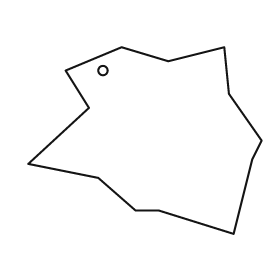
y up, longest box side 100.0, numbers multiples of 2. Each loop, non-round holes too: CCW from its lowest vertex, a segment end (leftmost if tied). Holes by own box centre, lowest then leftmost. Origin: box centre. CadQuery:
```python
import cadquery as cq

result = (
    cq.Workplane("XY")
    .moveTo(38.0, -40.0)
    .lineTo(46.0, -8.0)
    .lineTo(50.0, 0.0)
    .lineTo(36.0, 20.0)
    .lineTo(34.0, 40.0)
    .lineTo(10.0, 34.0)
    .lineTo(-10.0, 40.0)
    .lineTo(-34.0, 30.0)
    .lineTo(-24.0, 14.0)
    .lineTo(-50.0, -10.0)
    .lineTo(-20.0, -16.0)
    .lineTo(-4.0, -30.0)
    .lineTo(6.0, -30.0)
    .close()
    .moveTo(-18.0, 30.0)
    .circle(2.0)
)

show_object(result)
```